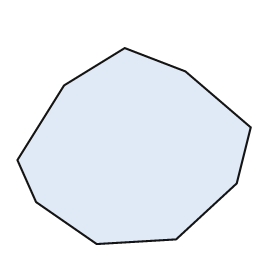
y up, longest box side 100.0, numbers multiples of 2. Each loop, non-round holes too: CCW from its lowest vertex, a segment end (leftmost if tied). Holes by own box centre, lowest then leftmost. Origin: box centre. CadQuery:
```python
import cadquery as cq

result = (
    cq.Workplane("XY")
    .moveTo(-16.0, -42.0)
    .lineTo(18.0, -40.0)
    .lineTo(44.0, -16.0)
    .lineTo(50.0, 8.0)
    .lineTo(22.0, 32.0)
    .lineTo(-4.0, 42.0)
    .lineTo(-30.0, 26.0)
    .lineTo(-50.0, -6.0)
    .lineTo(-42.0, -24.0)
    .close()
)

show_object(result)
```